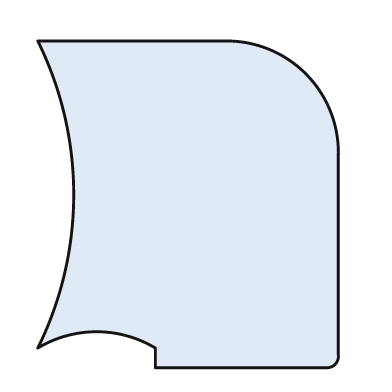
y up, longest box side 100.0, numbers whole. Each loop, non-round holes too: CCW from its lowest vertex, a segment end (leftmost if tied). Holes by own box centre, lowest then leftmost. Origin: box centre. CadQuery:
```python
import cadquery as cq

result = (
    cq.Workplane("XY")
    .moveTo(-10.0, -50.0)
    .lineTo(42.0, -50.0)
    .threePointArc((45.0, -49.0), (46.0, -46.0))
    .lineTo(46.0, 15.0)
    .threePointArc((36.0, 40.0), (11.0, 50.0))
    .lineTo(-46.0, 50.0)
    .threePointArc((-35.0, 3.0), (-46.0, -44.0))
    .threePointArc((-28.0, -39.0), (-10.0, -44.0))
    .close()
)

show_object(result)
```